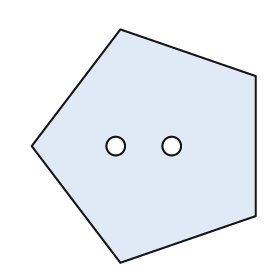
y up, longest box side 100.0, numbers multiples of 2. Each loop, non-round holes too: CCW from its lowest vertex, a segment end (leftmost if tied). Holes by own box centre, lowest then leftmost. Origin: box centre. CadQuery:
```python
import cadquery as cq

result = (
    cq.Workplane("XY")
    .moveTo(-10.0, -50.0)
    .lineTo(48.0, -30.0)
    .lineTo(48.0, 30.0)
    .lineTo(-10.0, 50.0)
    .lineTo(-48.0, 0.0)
    .close()
    .moveTo(-12.0, 0.0)
    .circle(4.0)
    .moveTo(12.0, 0.0)
    .circle(4.0)
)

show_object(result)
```